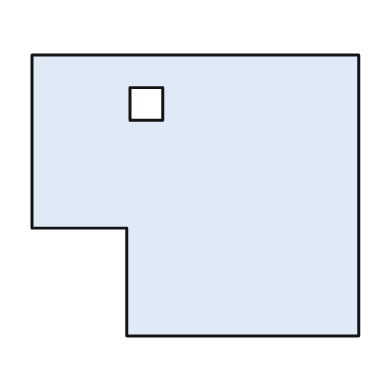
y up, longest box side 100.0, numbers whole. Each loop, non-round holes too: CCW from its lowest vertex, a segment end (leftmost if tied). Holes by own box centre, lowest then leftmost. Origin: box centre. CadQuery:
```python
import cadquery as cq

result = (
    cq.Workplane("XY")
    .moveTo(-21.0, -43.0)
    .lineTo(50.0, -43.0)
    .lineTo(50.0, 43.0)
    .lineTo(-50.0, 43.0)
    .lineTo(-50.0, -10.0)
    .lineTo(-21.0, -10.0)
    .close()
    .moveTo(-20.0, 23.0)
    .lineTo(-10.0, 23.0)
    .lineTo(-10.0, 33.0)
    .lineTo(-20.0, 33.0)
    .close()
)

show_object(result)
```